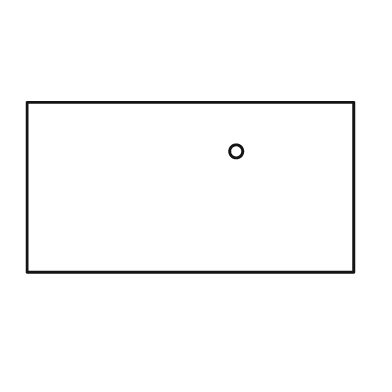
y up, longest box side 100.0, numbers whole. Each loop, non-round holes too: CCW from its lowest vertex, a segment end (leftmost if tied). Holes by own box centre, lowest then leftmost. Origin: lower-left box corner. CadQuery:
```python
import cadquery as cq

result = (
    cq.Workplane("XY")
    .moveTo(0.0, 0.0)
    .lineTo(100.0, 0.0)
    .lineTo(100.0, 52.0)
    .lineTo(0.0, 52.0)
    .close()
    .moveTo(64.0, 37.0)
    .circle(2.0)
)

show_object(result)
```